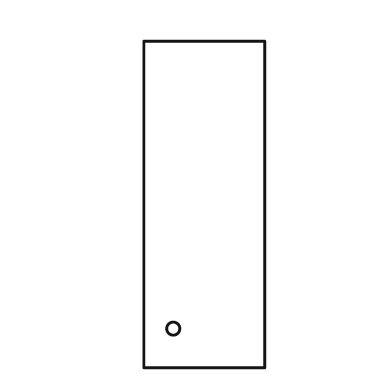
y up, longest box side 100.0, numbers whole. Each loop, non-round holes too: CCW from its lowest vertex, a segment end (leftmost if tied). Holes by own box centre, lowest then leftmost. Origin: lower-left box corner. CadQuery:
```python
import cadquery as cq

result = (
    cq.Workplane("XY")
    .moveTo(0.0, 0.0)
    .lineTo(37.0, 0.0)
    .lineTo(37.0, 100.0)
    .lineTo(0.0, 100.0)
    .close()
    .moveTo(9.0, 12.0)
    .circle(2.0)
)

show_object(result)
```